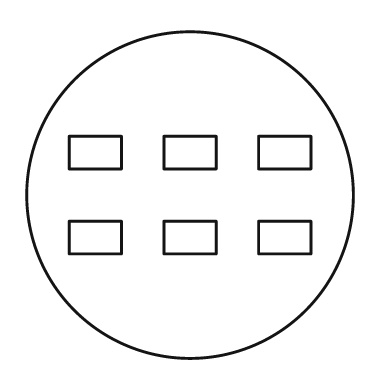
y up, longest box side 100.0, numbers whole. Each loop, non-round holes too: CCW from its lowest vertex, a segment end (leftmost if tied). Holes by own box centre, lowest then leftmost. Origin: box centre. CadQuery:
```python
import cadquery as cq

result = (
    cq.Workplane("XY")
    .moveTo(0.0, 0.0)
    .circle(50.0)
    .moveTo(-37.0, -18.0)
    .lineTo(-21.0, -18.0)
    .lineTo(-21.0, -8.0)
    .lineTo(-37.0, -8.0)
    .close()
    .moveTo(-8.0, -18.0)
    .lineTo(8.0, -18.0)
    .lineTo(8.0, -8.0)
    .lineTo(-8.0, -8.0)
    .close()
    .moveTo(21.0, -18.0)
    .lineTo(37.0, -18.0)
    .lineTo(37.0, -8.0)
    .lineTo(21.0, -8.0)
    .close()
    .moveTo(-37.0, 8.0)
    .lineTo(-21.0, 8.0)
    .lineTo(-21.0, 18.0)
    .lineTo(-37.0, 18.0)
    .close()
    .moveTo(-8.0, 8.0)
    .lineTo(8.0, 8.0)
    .lineTo(8.0, 18.0)
    .lineTo(-8.0, 18.0)
    .close()
    .moveTo(21.0, 8.0)
    .lineTo(37.0, 8.0)
    .lineTo(37.0, 18.0)
    .lineTo(21.0, 18.0)
    .close()
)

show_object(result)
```